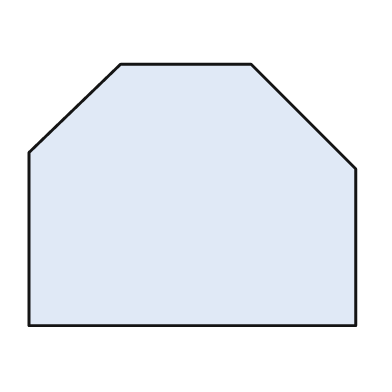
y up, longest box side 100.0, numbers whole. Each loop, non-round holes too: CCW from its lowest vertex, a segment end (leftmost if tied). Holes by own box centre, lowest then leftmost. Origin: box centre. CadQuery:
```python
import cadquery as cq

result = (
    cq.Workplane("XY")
    .moveTo(-50.0, -40.0)
    .lineTo(50.0, -40.0)
    .lineTo(50.0, 8.0)
    .lineTo(18.0, 40.0)
    .lineTo(-22.0, 40.0)
    .lineTo(-50.0, 13.0)
    .close()
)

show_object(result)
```